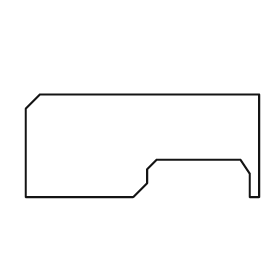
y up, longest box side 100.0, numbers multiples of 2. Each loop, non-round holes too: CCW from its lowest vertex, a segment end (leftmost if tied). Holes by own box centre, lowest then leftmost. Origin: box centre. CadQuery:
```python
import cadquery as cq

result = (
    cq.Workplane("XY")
    .moveTo(-50.0, -22.0)
    .lineTo(-4.0, -22.0)
    .lineTo(2.0, -16.0)
    .lineTo(2.0, -10.0)
    .lineTo(6.0, -6.0)
    .lineTo(42.0, -6.0)
    .lineTo(46.0, -12.0)
    .lineTo(46.0, -22.0)
    .lineTo(50.0, -22.0)
    .lineTo(50.0, 22.0)
    .lineTo(-44.0, 22.0)
    .lineTo(-50.0, 16.0)
    .close()
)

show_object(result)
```